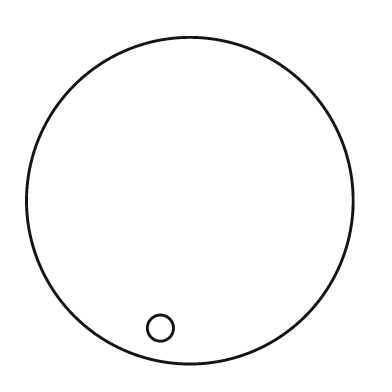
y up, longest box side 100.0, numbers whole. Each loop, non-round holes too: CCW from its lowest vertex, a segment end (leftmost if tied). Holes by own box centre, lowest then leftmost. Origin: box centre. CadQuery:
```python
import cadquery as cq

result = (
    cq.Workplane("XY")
    .moveTo(0.0, 0.0)
    .circle(50.0)
    .moveTo(-9.0, -39.0)
    .circle(4.0)
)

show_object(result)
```